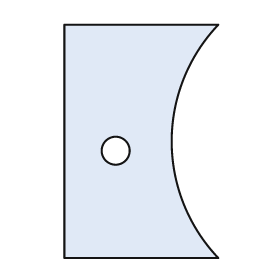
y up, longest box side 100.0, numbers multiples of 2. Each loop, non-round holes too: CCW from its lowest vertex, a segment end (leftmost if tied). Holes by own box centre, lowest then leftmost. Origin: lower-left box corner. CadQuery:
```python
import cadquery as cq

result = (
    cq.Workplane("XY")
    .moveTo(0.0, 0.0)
    .lineTo(66.0, 0.0)
    .threePointArc((46.0, 50.0), (66.0, 100.0))
    .lineTo(0.0, 100.0)
    .close()
    .moveTo(22.0, 46.0)
    .circle(6.0)
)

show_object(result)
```